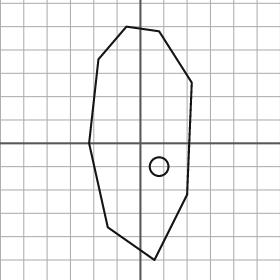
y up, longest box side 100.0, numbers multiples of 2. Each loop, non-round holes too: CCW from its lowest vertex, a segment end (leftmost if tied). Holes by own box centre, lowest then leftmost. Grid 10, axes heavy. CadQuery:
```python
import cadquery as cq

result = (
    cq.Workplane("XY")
    .moveTo(6.0, -50.0)
    .lineTo(20.0, -22.0)
    .lineTo(22.0, 26.0)
    .lineTo(8.0, 48.0)
    .lineTo(-6.0, 50.0)
    .lineTo(-18.0, 36.0)
    .lineTo(-22.0, 0.0)
    .lineTo(-14.0, -36.0)
    .close()
    .moveTo(8.0, -10.0)
    .circle(4.0)
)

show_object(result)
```